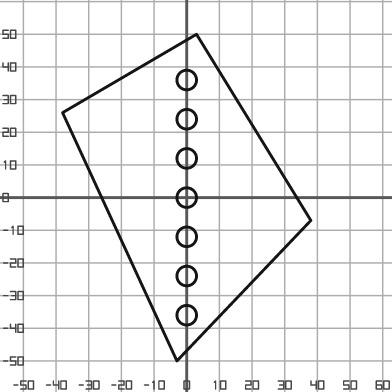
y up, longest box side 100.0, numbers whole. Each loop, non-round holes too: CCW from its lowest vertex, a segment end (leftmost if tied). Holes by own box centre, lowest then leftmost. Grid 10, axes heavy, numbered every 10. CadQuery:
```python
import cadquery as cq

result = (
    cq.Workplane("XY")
    .moveTo(-3.0, -50.0)
    .lineTo(38.0, -7.0)
    .lineTo(3.0, 50.0)
    .lineTo(-38.0, 26.0)
    .close()
    .moveTo(0.0, -36.0)
    .circle(3.0)
    .moveTo(0.0, -24.0)
    .circle(3.0)
    .moveTo(0.0, -12.0)
    .circle(3.0)
    .moveTo(0.0, 0.0)
    .circle(3.0)
    .moveTo(0.0, 12.0)
    .circle(3.0)
    .moveTo(0.0, 24.0)
    .circle(3.0)
    .moveTo(0.0, 36.0)
    .circle(3.0)
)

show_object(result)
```